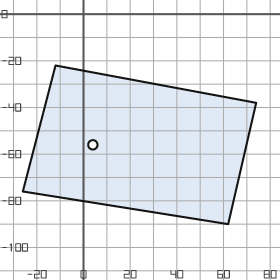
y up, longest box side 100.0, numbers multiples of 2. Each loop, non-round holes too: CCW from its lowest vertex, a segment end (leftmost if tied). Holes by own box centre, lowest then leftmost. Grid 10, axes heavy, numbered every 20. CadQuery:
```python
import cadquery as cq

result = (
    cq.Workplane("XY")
    .moveTo(62.0, -90.0)
    .lineTo(74.0, -38.0)
    .lineTo(-12.0, -22.0)
    .lineTo(-26.0, -76.0)
    .close()
    .moveTo(4.0, -56.0)
    .circle(2.0)
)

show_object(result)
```